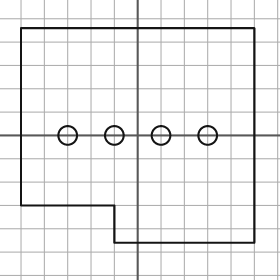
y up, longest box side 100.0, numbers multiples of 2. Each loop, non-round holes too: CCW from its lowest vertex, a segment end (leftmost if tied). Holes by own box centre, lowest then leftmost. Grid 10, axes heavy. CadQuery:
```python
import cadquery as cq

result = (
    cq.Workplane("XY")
    .moveTo(-10.0, -46.0)
    .lineTo(50.0, -46.0)
    .lineTo(50.0, 46.0)
    .lineTo(-50.0, 46.0)
    .lineTo(-50.0, -30.0)
    .lineTo(-10.0, -30.0)
    .close()
    .moveTo(-30.0, 0.0)
    .circle(4.0)
    .moveTo(-10.0, 0.0)
    .circle(4.0)
    .moveTo(10.0, 0.0)
    .circle(4.0)
    .moveTo(30.0, 0.0)
    .circle(4.0)
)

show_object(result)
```